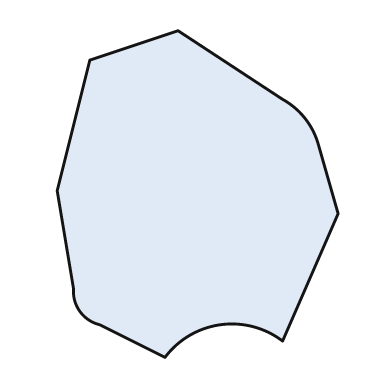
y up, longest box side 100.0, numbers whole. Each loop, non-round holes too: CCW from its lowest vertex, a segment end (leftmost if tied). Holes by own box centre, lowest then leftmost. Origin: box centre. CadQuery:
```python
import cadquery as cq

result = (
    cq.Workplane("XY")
    .moveTo(-10.0, -50.0)
    .threePointArc((7.0, -40.0), (26.0, -45.0))
    .lineTo(43.0, -6.0)
    .lineTo(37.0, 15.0)
    .threePointArc((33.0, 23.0), (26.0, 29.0))
    .lineTo(-6.0, 50.0)
    .lineTo(-33.0, 41.0)
    .lineTo(-43.0, 1.0)
    .lineTo(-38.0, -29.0)
    .threePointArc((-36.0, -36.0), (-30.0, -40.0))
    .close()
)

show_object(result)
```